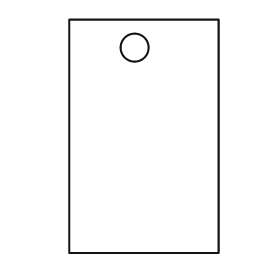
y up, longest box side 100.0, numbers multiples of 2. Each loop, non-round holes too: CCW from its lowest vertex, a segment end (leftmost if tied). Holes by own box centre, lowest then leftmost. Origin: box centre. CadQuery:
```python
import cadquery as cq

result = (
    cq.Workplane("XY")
    .moveTo(-32.0, -50.0)
    .lineTo(32.0, -50.0)
    .lineTo(32.0, 50.0)
    .lineTo(-32.0, 50.0)
    .close()
    .moveTo(-4.0, 38.0)
    .circle(6.0)
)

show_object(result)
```